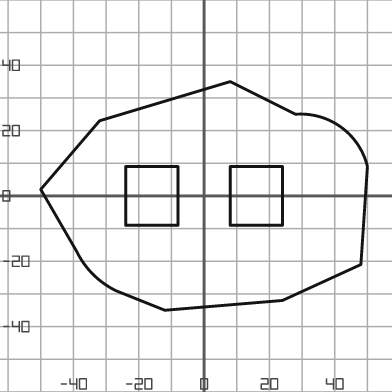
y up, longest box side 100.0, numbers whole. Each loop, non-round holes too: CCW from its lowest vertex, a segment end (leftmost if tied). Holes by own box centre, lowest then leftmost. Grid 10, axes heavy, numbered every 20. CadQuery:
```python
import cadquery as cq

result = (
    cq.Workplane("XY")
    .moveTo(-12.0, -35.0)
    .lineTo(24.0, -32.0)
    .lineTo(48.0, -21.0)
    .lineTo(50.0, 9.0)
    .threePointArc((42.0, 21.0), (28.0, 25.0))
    .lineTo(8.0, 35.0)
    .lineTo(-32.0, 23.0)
    .lineTo(-50.0, 2.0)
    .lineTo(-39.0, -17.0)
    .threePointArc((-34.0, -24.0), (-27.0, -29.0))
    .close()
    .moveTo(-24.0, -9.0)
    .lineTo(-8.0, -9.0)
    .lineTo(-8.0, 9.0)
    .lineTo(-24.0, 9.0)
    .close()
    .moveTo(8.0, -9.0)
    .lineTo(24.0, -9.0)
    .lineTo(24.0, 9.0)
    .lineTo(8.0, 9.0)
    .close()
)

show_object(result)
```